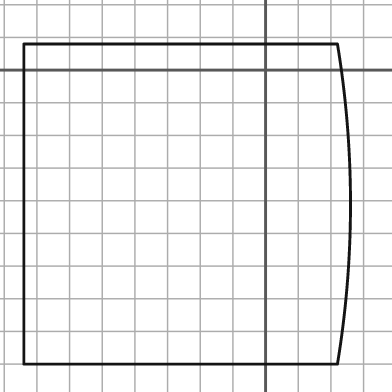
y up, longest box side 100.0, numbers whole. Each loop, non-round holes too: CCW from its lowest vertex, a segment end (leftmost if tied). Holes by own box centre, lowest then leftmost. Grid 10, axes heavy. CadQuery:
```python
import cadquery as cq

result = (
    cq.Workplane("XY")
    .moveTo(-74.0, -90.0)
    .lineTo(22.0, -90.0)
    .threePointArc((26.0, -41.0), (22.0, 8.0))
    .lineTo(-74.0, 8.0)
    .close()
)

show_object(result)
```